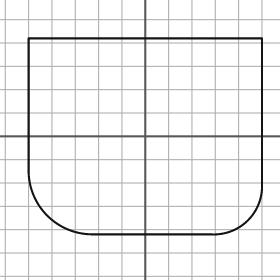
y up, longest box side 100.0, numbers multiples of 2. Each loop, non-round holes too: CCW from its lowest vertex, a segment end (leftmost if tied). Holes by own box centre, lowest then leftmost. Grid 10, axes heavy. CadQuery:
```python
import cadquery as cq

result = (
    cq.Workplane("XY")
    .moveTo(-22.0, -42.0)
    .lineTo(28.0, -42.0)
    .threePointArc((44.0, -36.0), (50.0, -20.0))
    .lineTo(50.0, 42.0)
    .lineTo(-50.0, 42.0)
    .lineTo(-50.0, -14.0)
    .threePointArc((-42.0, -34.0), (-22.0, -42.0))
    .close()
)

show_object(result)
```